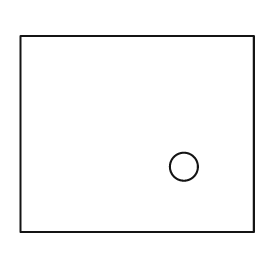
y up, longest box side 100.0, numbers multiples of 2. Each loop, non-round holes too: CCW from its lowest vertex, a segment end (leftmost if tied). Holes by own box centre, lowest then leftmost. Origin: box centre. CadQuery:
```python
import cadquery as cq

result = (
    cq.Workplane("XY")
    .moveTo(-50.0, -42.0)
    .lineTo(50.0, -42.0)
    .lineTo(50.0, 42.0)
    .lineTo(-50.0, 42.0)
    .close()
    .moveTo(20.0, -14.0)
    .circle(6.0)
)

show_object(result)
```